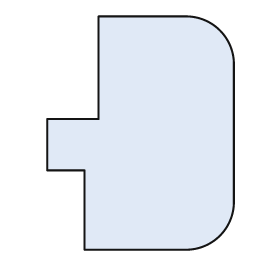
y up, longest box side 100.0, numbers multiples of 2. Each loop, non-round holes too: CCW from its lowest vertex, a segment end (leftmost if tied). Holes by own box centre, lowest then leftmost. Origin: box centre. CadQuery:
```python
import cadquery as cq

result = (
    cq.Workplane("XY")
    .moveTo(-24.0, -50.0)
    .lineTo(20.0, -50.0)
    .threePointArc((34.0, -44.0), (40.0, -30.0))
    .lineTo(40.0, 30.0)
    .threePointArc((34.0, 44.0), (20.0, 50.0))
    .lineTo(-18.0, 50.0)
    .lineTo(-18.0, 6.0)
    .lineTo(-40.0, 6.0)
    .lineTo(-40.0, -16.0)
    .lineTo(-24.0, -16.0)
    .close()
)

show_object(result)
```